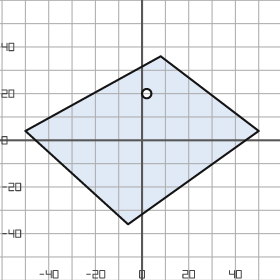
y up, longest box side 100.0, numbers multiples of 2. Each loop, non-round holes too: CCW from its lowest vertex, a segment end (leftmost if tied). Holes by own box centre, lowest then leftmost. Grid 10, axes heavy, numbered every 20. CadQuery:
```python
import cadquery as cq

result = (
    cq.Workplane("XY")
    .moveTo(-6.0, -36.0)
    .lineTo(50.0, 4.0)
    .lineTo(8.0, 36.0)
    .lineTo(-50.0, 4.0)
    .close()
    .moveTo(2.0, 20.0)
    .circle(2.0)
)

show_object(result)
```